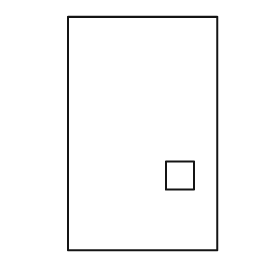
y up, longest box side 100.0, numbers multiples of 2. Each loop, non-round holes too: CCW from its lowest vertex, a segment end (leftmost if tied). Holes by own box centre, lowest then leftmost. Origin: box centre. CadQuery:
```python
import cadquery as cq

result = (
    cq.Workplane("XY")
    .moveTo(-32.0, -50.0)
    .lineTo(32.0, -50.0)
    .lineTo(32.0, 50.0)
    .lineTo(-32.0, 50.0)
    .close()
    .moveTo(10.0, -24.0)
    .lineTo(22.0, -24.0)
    .lineTo(22.0, -12.0)
    .lineTo(10.0, -12.0)
    .close()
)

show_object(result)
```